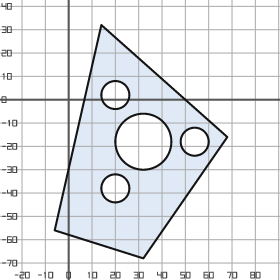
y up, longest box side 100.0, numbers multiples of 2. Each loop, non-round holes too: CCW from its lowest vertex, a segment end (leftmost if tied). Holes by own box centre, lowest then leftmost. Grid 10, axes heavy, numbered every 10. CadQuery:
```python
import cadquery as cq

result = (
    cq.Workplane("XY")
    .moveTo(32.0, -68.0)
    .lineTo(68.0, -16.0)
    .lineTo(14.0, 32.0)
    .lineTo(-6.0, -56.0)
    .close()
    .moveTo(20.0, -38.0)
    .circle(6.0)
    .moveTo(32.0, -18.0)
    .circle(12.0)
    .moveTo(54.0, -18.0)
    .circle(6.0)
    .moveTo(20.0, 2.0)
    .circle(6.0)
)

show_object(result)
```